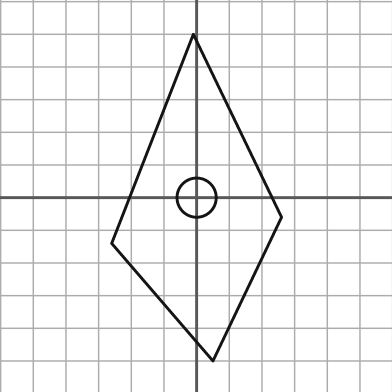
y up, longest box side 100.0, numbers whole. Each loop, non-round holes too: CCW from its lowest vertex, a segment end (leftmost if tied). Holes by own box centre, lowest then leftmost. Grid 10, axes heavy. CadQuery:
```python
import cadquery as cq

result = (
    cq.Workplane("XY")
    .moveTo(5.0, -50.0)
    .lineTo(26.0, -6.0)
    .lineTo(-1.0, 50.0)
    .lineTo(-26.0, -14.0)
    .close()
    .moveTo(0.0, 0.0)
    .circle(6.0)
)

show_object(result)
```